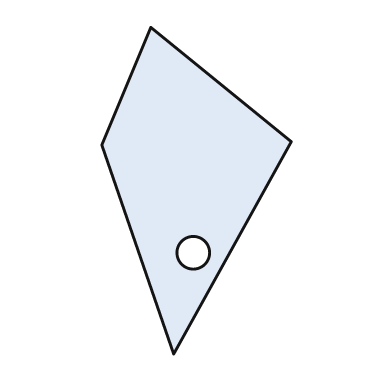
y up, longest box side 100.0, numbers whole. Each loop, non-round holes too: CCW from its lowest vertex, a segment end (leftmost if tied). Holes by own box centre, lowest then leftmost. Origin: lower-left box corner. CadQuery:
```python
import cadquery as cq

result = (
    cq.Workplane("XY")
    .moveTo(22.0, 0.0)
    .lineTo(58.0, 65.0)
    .lineTo(15.0, 100.0)
    .lineTo(0.0, 64.0)
    .close()
    .moveTo(28.0, 31.0)
    .circle(5.0)
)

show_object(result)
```